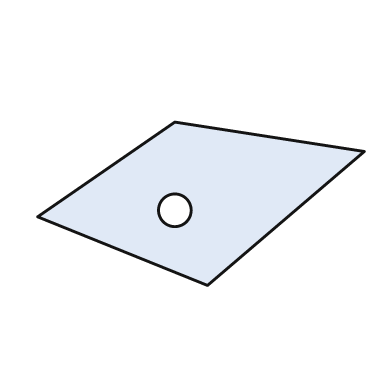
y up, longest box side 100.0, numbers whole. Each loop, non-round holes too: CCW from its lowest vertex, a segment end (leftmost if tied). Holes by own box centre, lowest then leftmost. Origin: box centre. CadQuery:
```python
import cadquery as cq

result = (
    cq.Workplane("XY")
    .moveTo(2.0, -25.0)
    .lineTo(50.0, 16.0)
    .lineTo(-8.0, 25.0)
    .lineTo(-50.0, -4.0)
    .close()
    .moveTo(-8.0, -2.0)
    .circle(5.0)
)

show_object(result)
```